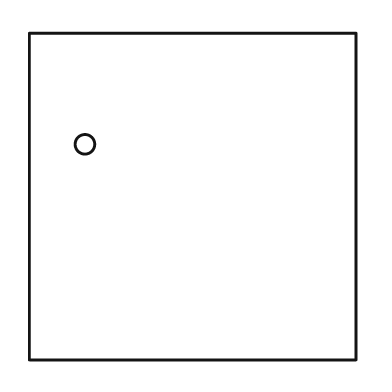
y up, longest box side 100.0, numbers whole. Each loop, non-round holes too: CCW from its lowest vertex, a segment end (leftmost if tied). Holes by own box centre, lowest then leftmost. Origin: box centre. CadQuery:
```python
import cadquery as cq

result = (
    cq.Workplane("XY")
    .moveTo(-50.0, -50.0)
    .lineTo(50.0, -50.0)
    .lineTo(50.0, 50.0)
    .lineTo(-50.0, 50.0)
    .close()
    .moveTo(-33.0, 16.0)
    .circle(3.0)
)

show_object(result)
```